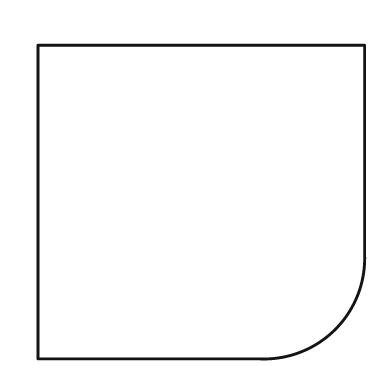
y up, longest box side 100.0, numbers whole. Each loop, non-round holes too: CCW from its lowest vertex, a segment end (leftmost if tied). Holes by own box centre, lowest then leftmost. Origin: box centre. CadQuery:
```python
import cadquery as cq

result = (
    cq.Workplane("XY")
    .moveTo(-50.0, -48.0)
    .lineTo(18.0, -48.0)
    .threePointArc((41.0, -39.0), (50.0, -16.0))
    .lineTo(50.0, 48.0)
    .lineTo(-50.0, 48.0)
    .close()
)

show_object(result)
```